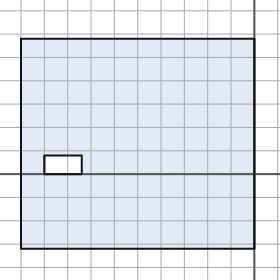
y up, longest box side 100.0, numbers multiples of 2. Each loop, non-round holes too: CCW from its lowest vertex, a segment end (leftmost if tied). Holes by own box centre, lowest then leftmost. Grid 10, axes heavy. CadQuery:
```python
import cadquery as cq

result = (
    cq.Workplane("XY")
    .moveTo(-100.0, -32.0)
    .lineTo(0.0, -32.0)
    .lineTo(0.0, 58.0)
    .lineTo(-100.0, 58.0)
    .close()
    .moveTo(-90.0, 0.0)
    .lineTo(-74.0, 0.0)
    .lineTo(-74.0, 8.0)
    .lineTo(-90.0, 8.0)
    .close()
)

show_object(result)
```